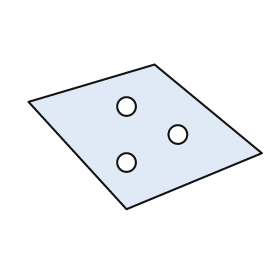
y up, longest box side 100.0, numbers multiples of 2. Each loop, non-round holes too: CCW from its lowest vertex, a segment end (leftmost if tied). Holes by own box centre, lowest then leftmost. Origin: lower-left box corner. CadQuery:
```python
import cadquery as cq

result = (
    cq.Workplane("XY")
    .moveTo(42.0, 0.0)
    .lineTo(100.0, 24.0)
    .lineTo(54.0, 62.0)
    .lineTo(0.0, 46.0)
    .close()
    .moveTo(42.0, 20.0)
    .circle(4.0)
    .moveTo(64.0, 32.0)
    .circle(4.0)
    .moveTo(42.0, 44.0)
    .circle(4.0)
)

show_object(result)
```